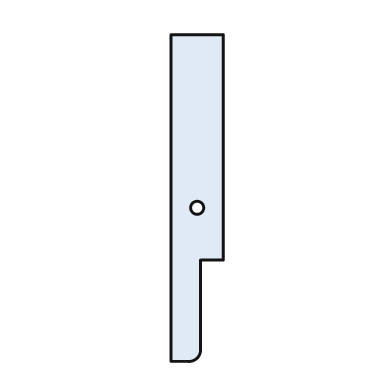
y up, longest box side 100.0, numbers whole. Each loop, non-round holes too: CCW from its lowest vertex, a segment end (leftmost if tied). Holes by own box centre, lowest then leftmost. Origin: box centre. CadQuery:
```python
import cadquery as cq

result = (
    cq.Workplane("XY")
    .moveTo(-8.0, -50.0)
    .lineTo(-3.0, -50.0)
    .threePointArc((0.0, -49.0), (1.0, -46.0))
    .lineTo(1.0, -19.0)
    .lineTo(8.0, -19.0)
    .lineTo(8.0, 50.0)
    .lineTo(-8.0, 50.0)
    .close()
    .moveTo(0.0, -3.0)
    .circle(2.0)
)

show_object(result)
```